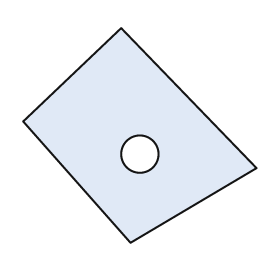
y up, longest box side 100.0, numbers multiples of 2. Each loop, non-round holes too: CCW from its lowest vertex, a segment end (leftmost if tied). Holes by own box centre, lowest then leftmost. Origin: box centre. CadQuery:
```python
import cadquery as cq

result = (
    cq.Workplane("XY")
    .moveTo(-4.0, -46.0)
    .lineTo(50.0, -14.0)
    .lineTo(-8.0, 46.0)
    .lineTo(-50.0, 6.0)
    .close()
    .moveTo(0.0, -8.0)
    .circle(8.0)
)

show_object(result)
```